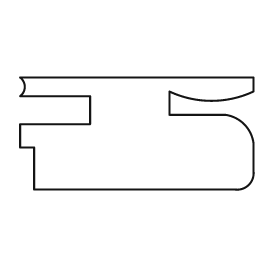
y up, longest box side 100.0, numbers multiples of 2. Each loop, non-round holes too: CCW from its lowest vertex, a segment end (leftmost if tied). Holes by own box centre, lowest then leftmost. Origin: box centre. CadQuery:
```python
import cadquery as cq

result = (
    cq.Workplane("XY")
    .moveTo(-44.0, -24.0)
    .lineTo(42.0, -24.0)
    .threePointArc((48.0, -22.0), (50.0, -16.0))
    .lineTo(50.0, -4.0)
    .threePointArc((46.0, 4.0), (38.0, 8.0))
    .lineTo(14.0, 8.0)
    .lineTo(14.0, 18.0)
    .threePointArc((32.0, 14.0), (50.0, 18.0))
    .lineTo(50.0, 24.0)
    .lineTo(-50.0, 24.0)
    .threePointArc((-48.0, 20.0), (-50.0, 16.0))
    .lineTo(-20.0, 16.0)
    .lineTo(-20.0, 4.0)
    .lineTo(-50.0, 4.0)
    .lineTo(-50.0, -6.0)
    .lineTo(-44.0, -6.0)
    .close()
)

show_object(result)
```